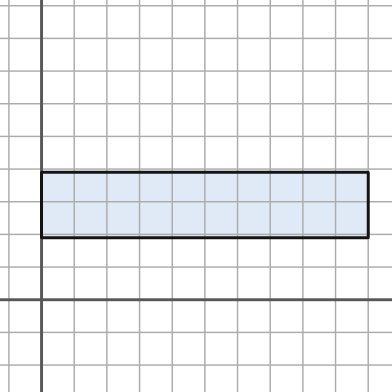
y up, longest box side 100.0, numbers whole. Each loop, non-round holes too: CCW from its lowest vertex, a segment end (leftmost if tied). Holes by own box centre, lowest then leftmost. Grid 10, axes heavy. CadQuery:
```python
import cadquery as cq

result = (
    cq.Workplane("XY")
    .moveTo(0.0, 19.0)
    .lineTo(100.0, 19.0)
    .lineTo(100.0, 39.0)
    .lineTo(0.0, 39.0)
    .close()
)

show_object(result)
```